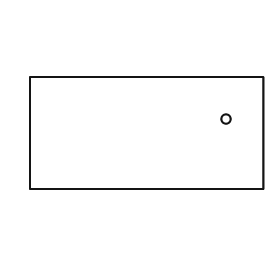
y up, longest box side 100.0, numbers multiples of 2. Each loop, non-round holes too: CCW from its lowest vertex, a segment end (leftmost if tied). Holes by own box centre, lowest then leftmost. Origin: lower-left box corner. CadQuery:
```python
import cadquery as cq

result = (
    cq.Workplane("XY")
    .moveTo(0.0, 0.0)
    .lineTo(100.0, 0.0)
    .lineTo(100.0, 48.0)
    .lineTo(0.0, 48.0)
    .close()
    .moveTo(84.0, 30.0)
    .circle(2.0)
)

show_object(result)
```